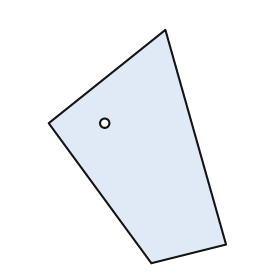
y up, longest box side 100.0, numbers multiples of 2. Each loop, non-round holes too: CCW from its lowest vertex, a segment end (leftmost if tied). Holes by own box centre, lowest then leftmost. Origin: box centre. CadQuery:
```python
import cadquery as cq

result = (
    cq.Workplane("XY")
    .moveTo(6.0, -50.0)
    .lineTo(38.0, -42.0)
    .lineTo(12.0, 50.0)
    .lineTo(-38.0, 10.0)
    .close()
    .moveTo(-14.0, 10.0)
    .circle(2.0)
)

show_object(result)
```